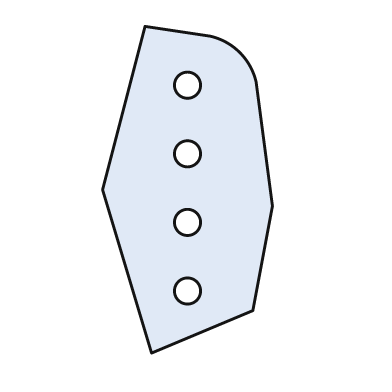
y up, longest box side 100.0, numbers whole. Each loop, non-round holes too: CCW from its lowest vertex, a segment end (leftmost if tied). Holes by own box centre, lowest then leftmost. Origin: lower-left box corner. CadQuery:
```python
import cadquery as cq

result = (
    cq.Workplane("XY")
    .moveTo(15.0, 0.0)
    .lineTo(46.0, 13.0)
    .lineTo(52.0, 45.0)
    .lineTo(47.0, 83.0)
    .threePointArc((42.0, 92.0), (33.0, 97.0))
    .lineTo(13.0, 100.0)
    .lineTo(0.0, 50.0)
    .close()
    .moveTo(26.0, 19.0)
    .circle(4.0)
    .moveTo(26.0, 40.0)
    .circle(4.0)
    .moveTo(26.0, 61.0)
    .circle(4.0)
    .moveTo(26.0, 82.0)
    .circle(4.0)
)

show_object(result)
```